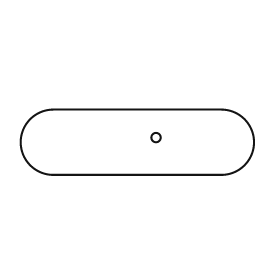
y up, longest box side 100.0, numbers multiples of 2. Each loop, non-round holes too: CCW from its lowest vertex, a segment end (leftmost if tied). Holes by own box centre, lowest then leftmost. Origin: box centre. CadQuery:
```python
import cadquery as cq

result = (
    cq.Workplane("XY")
    .moveTo(-36.0, -14.0)
    .lineTo(36.0, -14.0)
    .threePointArc((50.0, 0.0), (36.0, 14.0))
    .lineTo(-36.0, 14.0)
    .threePointArc((-50.0, 0.0), (-36.0, -14.0))
    .close()
    .moveTo(8.0, 2.0)
    .circle(2.0)
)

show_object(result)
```